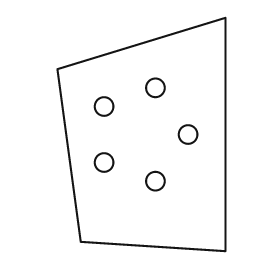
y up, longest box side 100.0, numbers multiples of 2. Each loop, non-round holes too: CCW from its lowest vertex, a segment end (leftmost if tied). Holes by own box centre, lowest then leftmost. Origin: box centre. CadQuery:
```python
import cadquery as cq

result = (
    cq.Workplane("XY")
    .moveTo(36.0, -50.0)
    .lineTo(36.0, 50.0)
    .lineTo(-36.0, 28.0)
    .lineTo(-26.0, -46.0)
    .close()
    .moveTo(6.0, -20.0)
    .circle(4.0)
    .moveTo(-16.0, -12.0)
    .circle(4.0)
    .moveTo(20.0, 0.0)
    .circle(4.0)
    .moveTo(-16.0, 12.0)
    .circle(4.0)
    .moveTo(6.0, 20.0)
    .circle(4.0)
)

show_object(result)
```